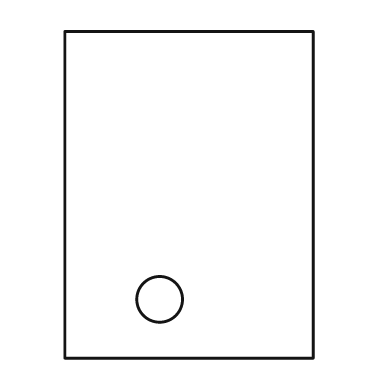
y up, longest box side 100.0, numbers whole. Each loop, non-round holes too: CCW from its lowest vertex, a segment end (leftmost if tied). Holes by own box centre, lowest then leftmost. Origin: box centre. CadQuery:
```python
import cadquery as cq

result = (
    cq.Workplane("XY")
    .moveTo(-38.0, -50.0)
    .lineTo(38.0, -50.0)
    .lineTo(38.0, 50.0)
    .lineTo(-38.0, 50.0)
    .close()
    .moveTo(-9.0, -32.0)
    .circle(7.0)
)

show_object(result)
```